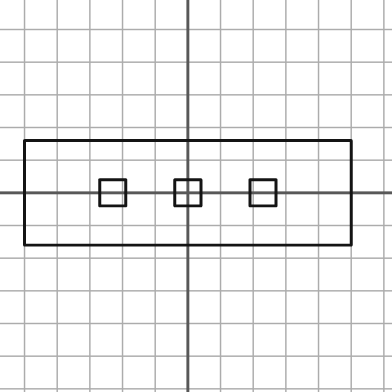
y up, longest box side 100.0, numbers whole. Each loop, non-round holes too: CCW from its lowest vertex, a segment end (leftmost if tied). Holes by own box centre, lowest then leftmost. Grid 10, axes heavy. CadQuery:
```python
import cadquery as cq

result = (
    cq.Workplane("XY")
    .moveTo(-50.0, -16.0)
    .lineTo(50.0, -16.0)
    .lineTo(50.0, 16.0)
    .lineTo(-50.0, 16.0)
    .close()
    .moveTo(-27.0, -4.0)
    .lineTo(-19.0, -4.0)
    .lineTo(-19.0, 4.0)
    .lineTo(-27.0, 4.0)
    .close()
    .moveTo(-4.0, -4.0)
    .lineTo(4.0, -4.0)
    .lineTo(4.0, 4.0)
    .lineTo(-4.0, 4.0)
    .close()
    .moveTo(19.0, -4.0)
    .lineTo(27.0, -4.0)
    .lineTo(27.0, 4.0)
    .lineTo(19.0, 4.0)
    .close()
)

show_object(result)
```